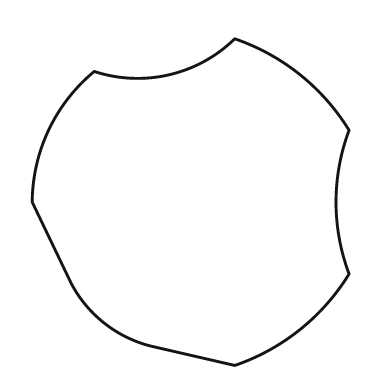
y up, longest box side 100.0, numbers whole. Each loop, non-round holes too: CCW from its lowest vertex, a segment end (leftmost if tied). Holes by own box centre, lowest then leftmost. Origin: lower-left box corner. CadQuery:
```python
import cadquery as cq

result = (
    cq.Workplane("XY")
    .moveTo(62.0, 0.0)
    .threePointArc((82.0, 11.0), (97.0, 28.0))
    .threePointArc((93.0, 50.0), (97.0, 72.0))
    .threePointArc((82.0, 89.0), (62.0, 100.0))
    .threePointArc((42.0, 89.0), (19.0, 90.0))
    .threePointArc((5.0, 72.0), (0.0, 50.0))
    .lineTo(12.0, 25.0)
    .threePointArc((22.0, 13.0), (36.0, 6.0))
    .close()
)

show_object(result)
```